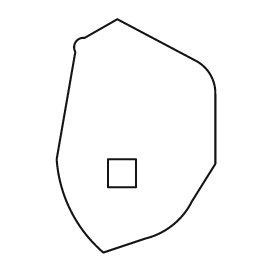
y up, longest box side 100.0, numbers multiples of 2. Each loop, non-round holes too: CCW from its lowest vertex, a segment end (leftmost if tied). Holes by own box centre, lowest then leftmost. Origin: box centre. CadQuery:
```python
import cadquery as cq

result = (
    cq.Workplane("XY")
    .moveTo(-14.0, -50.0)
    .lineTo(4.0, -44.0)
    .threePointArc((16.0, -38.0), (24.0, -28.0))
    .lineTo(34.0, -12.0)
    .lineTo(34.0, 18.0)
    .threePointArc((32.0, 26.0), (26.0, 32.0))
    .lineTo(-8.0, 50.0)
    .lineTo(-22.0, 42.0)
    .threePointArc((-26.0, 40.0), (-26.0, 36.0))
    .lineTo(-34.0, -10.0)
    .threePointArc((-28.0, -32.0), (-14.0, -50.0))
    .close()
    .moveTo(-12.0, -22.0)
    .lineTo(0.0, -22.0)
    .lineTo(0.0, -10.0)
    .lineTo(-12.0, -10.0)
    .close()
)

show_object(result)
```